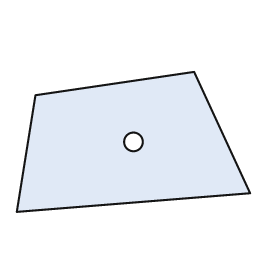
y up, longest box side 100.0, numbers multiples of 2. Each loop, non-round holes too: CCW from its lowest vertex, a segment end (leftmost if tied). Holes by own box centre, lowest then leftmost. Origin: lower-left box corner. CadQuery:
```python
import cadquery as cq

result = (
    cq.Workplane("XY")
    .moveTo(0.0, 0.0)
    .lineTo(100.0, 8.0)
    .lineTo(76.0, 60.0)
    .lineTo(8.0, 50.0)
    .close()
    .moveTo(50.0, 30.0)
    .circle(4.0)
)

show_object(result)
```